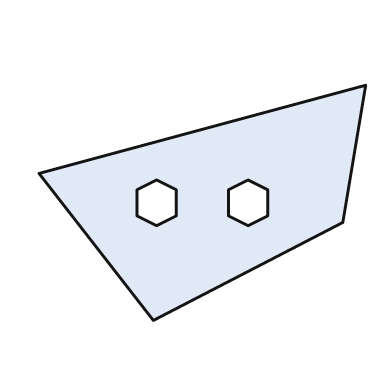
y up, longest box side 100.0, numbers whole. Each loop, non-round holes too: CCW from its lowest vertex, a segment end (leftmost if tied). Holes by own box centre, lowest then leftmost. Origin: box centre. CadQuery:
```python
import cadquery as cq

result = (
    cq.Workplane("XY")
    .moveTo(-15.0, -36.0)
    .lineTo(43.0, -6.0)
    .lineTo(50.0, 36.0)
    .lineTo(-50.0, 9.0)
    .close()
    .moveTo(-14.0, -7.0)
    .lineTo(-8.0, -4.0)
    .lineTo(-8.0, 4.0)
    .lineTo(-14.0, 7.0)
    .lineTo(-20.0, 4.0)
    .lineTo(-20.0, -4.0)
    .close()
    .moveTo(14.0, -7.0)
    .lineTo(20.0, -4.0)
    .lineTo(20.0, 4.0)
    .lineTo(14.0, 7.0)
    .lineTo(8.0, 4.0)
    .lineTo(8.0, -4.0)
    .close()
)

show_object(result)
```